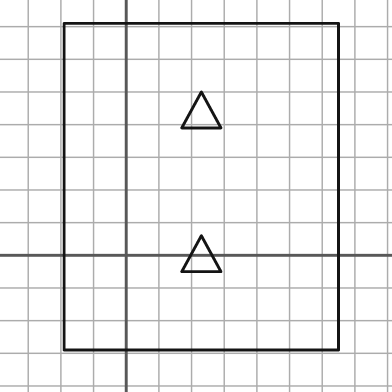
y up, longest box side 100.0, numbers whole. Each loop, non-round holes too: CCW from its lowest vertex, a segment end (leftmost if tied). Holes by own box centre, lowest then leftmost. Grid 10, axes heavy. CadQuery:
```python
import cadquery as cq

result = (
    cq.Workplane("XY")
    .moveTo(-19.0, -29.0)
    .lineTo(65.0, -29.0)
    .lineTo(65.0, 71.0)
    .lineTo(-19.0, 71.0)
    .close()
    .moveTo(17.0, -5.0)
    .lineTo(29.0, -5.0)
    .lineTo(23.0, 6.0)
    .close()
    .moveTo(17.0, 39.0)
    .lineTo(29.0, 39.0)
    .lineTo(23.0, 50.0)
    .close()
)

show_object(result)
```